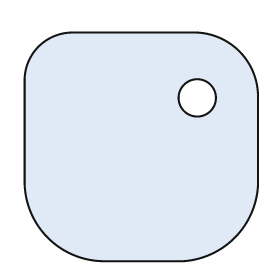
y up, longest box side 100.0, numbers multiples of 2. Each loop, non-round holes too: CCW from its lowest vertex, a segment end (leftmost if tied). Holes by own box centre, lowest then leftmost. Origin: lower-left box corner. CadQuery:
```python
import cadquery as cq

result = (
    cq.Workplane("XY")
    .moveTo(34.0, 0.0)
    .lineTo(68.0, 0.0)
    .threePointArc((90.0, 10.0), (100.0, 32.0))
    .lineTo(100.0, 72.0)
    .threePointArc((92.0, 90.0), (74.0, 98.0))
    .lineTo(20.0, 98.0)
    .threePointArc((6.0, 92.0), (0.0, 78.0))
    .lineTo(0.0, 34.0)
    .threePointArc((10.0, 10.0), (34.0, 0.0))
    .close()
    .moveTo(74.0, 70.0)
    .circle(8.0)
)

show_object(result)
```